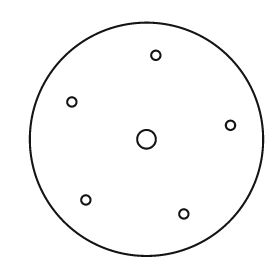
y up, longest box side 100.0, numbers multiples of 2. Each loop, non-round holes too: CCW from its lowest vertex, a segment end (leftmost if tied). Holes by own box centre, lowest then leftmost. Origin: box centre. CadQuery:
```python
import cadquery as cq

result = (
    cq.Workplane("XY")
    .moveTo(0.0, 0.0)
    .circle(50.0)
    .moveTo(16.0, -32.0)
    .circle(2.0)
    .moveTo(-26.0, -26.0)
    .circle(2.0)
    .moveTo(0.0, 0.0)
    .circle(4.0)
    .moveTo(36.0, 6.0)
    .circle(2.0)
    .moveTo(-32.0, 16.0)
    .circle(2.0)
    .moveTo(4.0, 36.0)
    .circle(2.0)
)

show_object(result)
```